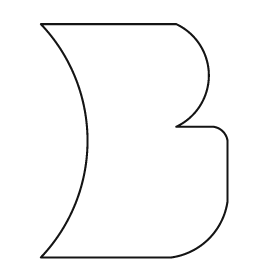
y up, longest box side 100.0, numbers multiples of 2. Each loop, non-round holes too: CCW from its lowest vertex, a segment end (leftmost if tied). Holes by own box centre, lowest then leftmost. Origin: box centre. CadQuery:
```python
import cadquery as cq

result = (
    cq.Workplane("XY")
    .moveTo(-40.0, -50.0)
    .lineTo(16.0, -50.0)
    .threePointArc((32.0, -42.0), (40.0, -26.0))
    .lineTo(40.0, 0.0)
    .threePointArc((38.0, 4.0), (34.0, 6.0))
    .lineTo(18.0, 6.0)
    .threePointArc((32.0, 28.0), (18.0, 50.0))
    .lineTo(-40.0, 50.0)
    .threePointArc((-20.0, 0.0), (-40.0, -50.0))
    .close()
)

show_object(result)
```